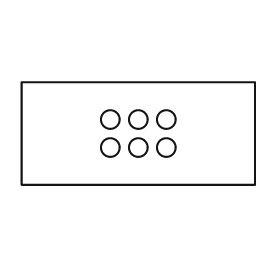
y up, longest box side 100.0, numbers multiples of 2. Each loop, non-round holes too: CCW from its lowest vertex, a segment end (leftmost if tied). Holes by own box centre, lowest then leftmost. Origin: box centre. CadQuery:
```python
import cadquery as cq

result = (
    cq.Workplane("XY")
    .moveTo(-50.0, -22.0)
    .lineTo(50.0, -22.0)
    .lineTo(50.0, 22.0)
    .lineTo(-50.0, 22.0)
    .close()
    .moveTo(-12.0, -6.0)
    .circle(4.0)
    .moveTo(0.0, -6.0)
    .circle(4.0)
    .moveTo(12.0, -6.0)
    .circle(4.0)
    .moveTo(-12.0, 6.0)
    .circle(4.0)
    .moveTo(0.0, 6.0)
    .circle(4.0)
    .moveTo(12.0, 6.0)
    .circle(4.0)
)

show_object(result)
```